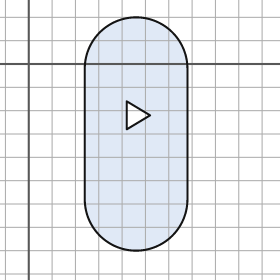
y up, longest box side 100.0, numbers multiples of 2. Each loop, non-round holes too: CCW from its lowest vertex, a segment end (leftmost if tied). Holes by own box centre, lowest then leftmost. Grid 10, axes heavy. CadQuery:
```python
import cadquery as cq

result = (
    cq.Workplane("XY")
    .moveTo(24.0, -58.0)
    .threePointArc((46.0, -80.0), (68.0, -58.0))
    .lineTo(68.0, -2.0)
    .threePointArc((46.0, 20.0), (24.0, -2.0))
    .close()
    .moveTo(42.0, -28.0)
    .lineTo(52.0, -22.0)
    .lineTo(42.0, -16.0)
    .close()
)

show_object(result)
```